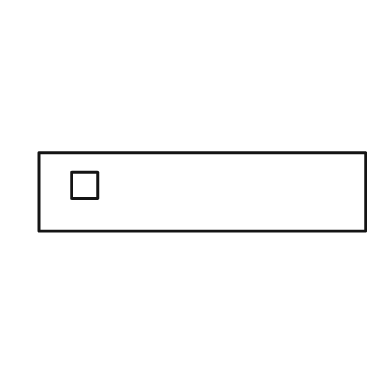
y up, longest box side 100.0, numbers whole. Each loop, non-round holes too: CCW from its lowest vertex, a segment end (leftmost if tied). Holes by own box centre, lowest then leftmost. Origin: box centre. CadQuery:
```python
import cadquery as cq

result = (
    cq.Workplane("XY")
    .moveTo(-50.0, -12.0)
    .lineTo(50.0, -12.0)
    .lineTo(50.0, 12.0)
    .lineTo(-50.0, 12.0)
    .close()
    .moveTo(-40.0, -2.0)
    .lineTo(-32.0, -2.0)
    .lineTo(-32.0, 6.0)
    .lineTo(-40.0, 6.0)
    .close()
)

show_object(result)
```